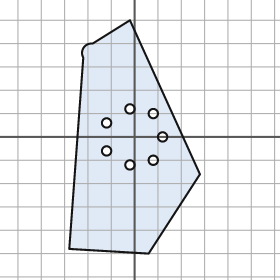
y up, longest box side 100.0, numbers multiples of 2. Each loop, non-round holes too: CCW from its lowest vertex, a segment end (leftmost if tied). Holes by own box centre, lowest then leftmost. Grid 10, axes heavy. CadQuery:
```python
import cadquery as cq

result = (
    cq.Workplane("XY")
    .moveTo(6.0, -50.0)
    .lineTo(28.0, -16.0)
    .lineTo(-2.0, 50.0)
    .lineTo(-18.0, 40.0)
    .threePointArc((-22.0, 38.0), (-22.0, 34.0))
    .lineTo(-28.0, -48.0)
    .close()
    .moveTo(-2.0, -12.0)
    .circle(2.0)
    .moveTo(8.0, -10.0)
    .circle(2.0)
    .moveTo(-12.0, -6.0)
    .circle(2.0)
    .moveTo(12.0, 0.0)
    .circle(2.0)
    .moveTo(-12.0, 6.0)
    .circle(2.0)
    .moveTo(8.0, 10.0)
    .circle(2.0)
    .moveTo(-2.0, 12.0)
    .circle(2.0)
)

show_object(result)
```